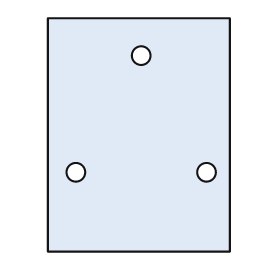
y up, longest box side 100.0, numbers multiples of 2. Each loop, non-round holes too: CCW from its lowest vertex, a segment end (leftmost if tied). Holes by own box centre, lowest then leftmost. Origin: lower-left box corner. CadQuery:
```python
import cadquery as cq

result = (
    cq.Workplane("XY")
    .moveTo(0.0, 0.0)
    .lineTo(78.0, 0.0)
    .lineTo(78.0, 100.0)
    .lineTo(0.0, 100.0)
    .close()
    .moveTo(12.0, 34.0)
    .circle(4.0)
    .moveTo(68.0, 34.0)
    .circle(4.0)
    .moveTo(40.0, 84.0)
    .circle(4.0)
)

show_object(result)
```